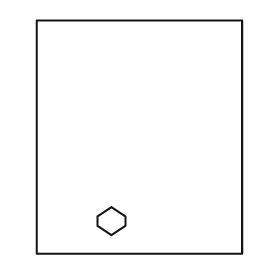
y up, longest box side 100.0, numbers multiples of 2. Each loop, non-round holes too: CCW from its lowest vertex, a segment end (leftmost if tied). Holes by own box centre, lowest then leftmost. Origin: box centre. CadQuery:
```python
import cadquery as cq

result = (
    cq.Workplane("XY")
    .moveTo(-44.0, -50.0)
    .lineTo(44.0, -50.0)
    .lineTo(44.0, 50.0)
    .lineTo(-44.0, 50.0)
    .close()
    .moveTo(-12.0, -42.0)
    .lineTo(-6.0, -38.0)
    .lineTo(-6.0, -34.0)
    .lineTo(-12.0, -30.0)
    .lineTo(-18.0, -34.0)
    .lineTo(-18.0, -38.0)
    .close()
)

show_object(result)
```